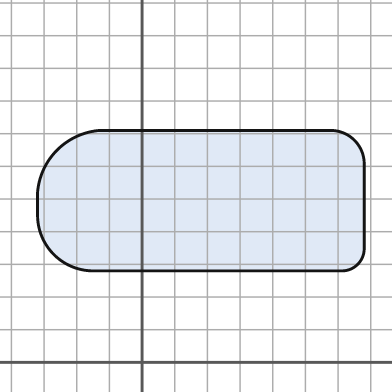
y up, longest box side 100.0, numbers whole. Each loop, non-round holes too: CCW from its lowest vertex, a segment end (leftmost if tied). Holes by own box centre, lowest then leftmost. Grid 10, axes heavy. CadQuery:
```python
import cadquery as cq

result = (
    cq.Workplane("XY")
    .moveTo(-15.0, 28.0)
    .lineTo(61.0, 28.0)
    .threePointArc((66.0, 30.0), (68.0, 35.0))
    .lineTo(68.0, 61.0)
    .threePointArc((65.0, 68.0), (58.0, 71.0))
    .lineTo(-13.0, 71.0)
    .threePointArc((-26.0, 65.0), (-32.0, 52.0))
    .lineTo(-32.0, 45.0)
    .threePointArc((-27.0, 33.0), (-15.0, 28.0))
    .close()
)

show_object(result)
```